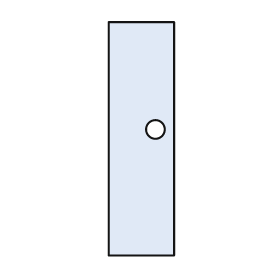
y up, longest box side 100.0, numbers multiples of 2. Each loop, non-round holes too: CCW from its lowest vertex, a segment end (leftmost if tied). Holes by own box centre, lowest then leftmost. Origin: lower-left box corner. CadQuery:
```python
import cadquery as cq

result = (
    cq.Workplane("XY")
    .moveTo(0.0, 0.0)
    .lineTo(28.0, 0.0)
    .lineTo(28.0, 100.0)
    .lineTo(0.0, 100.0)
    .close()
    .moveTo(20.0, 54.0)
    .circle(4.0)
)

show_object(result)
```